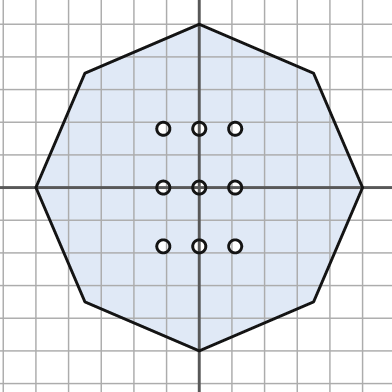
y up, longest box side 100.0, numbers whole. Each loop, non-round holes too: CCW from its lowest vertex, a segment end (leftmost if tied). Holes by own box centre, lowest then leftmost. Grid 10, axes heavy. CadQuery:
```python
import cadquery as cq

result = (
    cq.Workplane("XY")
    .moveTo(0.0, -50.0)
    .lineTo(35.0, -35.0)
    .lineTo(50.0, 0.0)
    .lineTo(35.0, 35.0)
    .lineTo(0.0, 50.0)
    .lineTo(-35.0, 35.0)
    .lineTo(-50.0, 0.0)
    .lineTo(-35.0, -35.0)
    .close()
    .moveTo(-11.0, -18.0)
    .circle(2.0)
    .moveTo(0.0, -18.0)
    .circle(2.0)
    .moveTo(11.0, -18.0)
    .circle(2.0)
    .moveTo(-11.0, 0.0)
    .circle(2.0)
    .moveTo(0.0, 0.0)
    .circle(2.0)
    .moveTo(11.0, 0.0)
    .circle(2.0)
    .moveTo(-11.0, 18.0)
    .circle(2.0)
    .moveTo(0.0, 18.0)
    .circle(2.0)
    .moveTo(11.0, 18.0)
    .circle(2.0)
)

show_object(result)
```